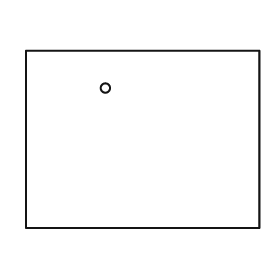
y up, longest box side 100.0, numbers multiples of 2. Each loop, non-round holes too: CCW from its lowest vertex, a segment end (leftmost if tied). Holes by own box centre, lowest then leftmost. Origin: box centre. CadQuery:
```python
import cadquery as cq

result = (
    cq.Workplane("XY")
    .moveTo(-50.0, -38.0)
    .lineTo(50.0, -38.0)
    .lineTo(50.0, 38.0)
    .lineTo(-50.0, 38.0)
    .close()
    .moveTo(-16.0, 22.0)
    .circle(2.0)
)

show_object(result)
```